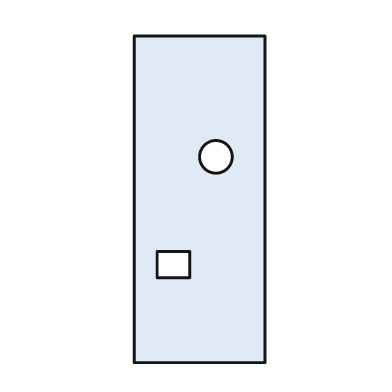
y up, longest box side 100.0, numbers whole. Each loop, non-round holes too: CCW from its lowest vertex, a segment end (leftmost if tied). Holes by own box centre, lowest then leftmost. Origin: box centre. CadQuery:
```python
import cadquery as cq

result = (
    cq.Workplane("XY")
    .moveTo(-20.0, -50.0)
    .lineTo(20.0, -50.0)
    .lineTo(20.0, 50.0)
    .lineTo(-20.0, 50.0)
    .close()
    .moveTo(-13.0, -24.0)
    .lineTo(-3.0, -24.0)
    .lineTo(-3.0, -16.0)
    .lineTo(-13.0, -16.0)
    .close()
    .moveTo(5.0, 13.0)
    .circle(5.0)
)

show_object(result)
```